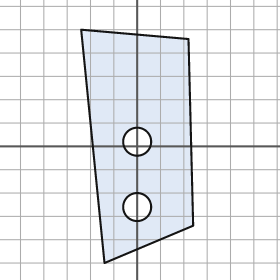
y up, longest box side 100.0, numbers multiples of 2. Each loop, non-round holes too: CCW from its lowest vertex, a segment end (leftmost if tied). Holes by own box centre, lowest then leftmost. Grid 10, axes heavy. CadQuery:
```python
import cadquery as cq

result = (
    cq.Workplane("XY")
    .moveTo(-14.0, -50.0)
    .lineTo(24.0, -34.0)
    .lineTo(22.0, 46.0)
    .lineTo(-24.0, 50.0)
    .close()
    .moveTo(0.0, -26.0)
    .circle(6.0)
    .moveTo(0.0, 2.0)
    .circle(6.0)
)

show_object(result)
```